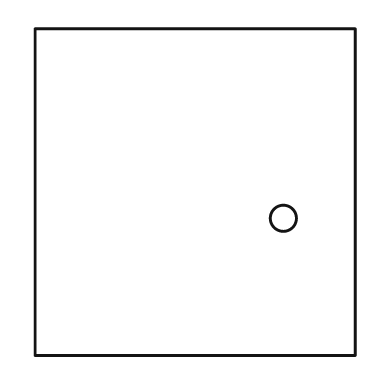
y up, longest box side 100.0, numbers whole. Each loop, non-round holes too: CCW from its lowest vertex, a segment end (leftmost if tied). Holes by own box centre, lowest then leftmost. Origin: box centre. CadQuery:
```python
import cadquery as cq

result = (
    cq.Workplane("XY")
    .moveTo(-49.0, -50.0)
    .lineTo(49.0, -50.0)
    .lineTo(49.0, 50.0)
    .lineTo(-49.0, 50.0)
    .close()
    .moveTo(27.0, -8.0)
    .circle(4.0)
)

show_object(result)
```